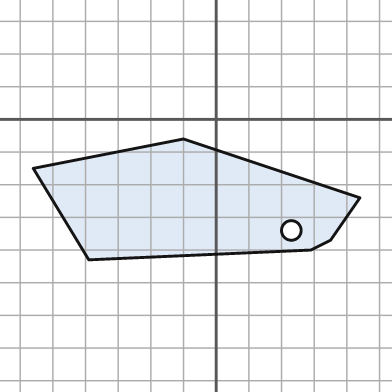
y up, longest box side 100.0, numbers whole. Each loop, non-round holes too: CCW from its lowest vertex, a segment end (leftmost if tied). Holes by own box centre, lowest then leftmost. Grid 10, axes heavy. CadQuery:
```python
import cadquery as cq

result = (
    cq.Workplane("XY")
    .moveTo(-39.0, -43.0)
    .lineTo(29.0, -40.0)
    .lineTo(35.0, -37.0)
    .lineTo(44.0, -24.0)
    .lineTo(-10.0, -6.0)
    .lineTo(-56.0, -15.0)
    .close()
    .moveTo(23.0, -34.0)
    .circle(3.0)
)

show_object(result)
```